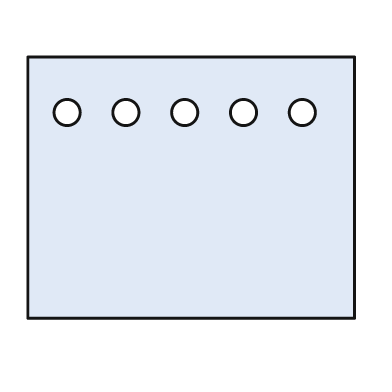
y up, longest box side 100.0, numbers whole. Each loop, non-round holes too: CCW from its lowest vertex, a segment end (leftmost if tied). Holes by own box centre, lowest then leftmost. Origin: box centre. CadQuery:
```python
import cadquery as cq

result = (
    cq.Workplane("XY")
    .moveTo(-50.0, -40.0)
    .lineTo(50.0, -40.0)
    .lineTo(50.0, 40.0)
    .lineTo(-50.0, 40.0)
    .close()
    .moveTo(-38.0, 23.0)
    .circle(4.0)
    .moveTo(-20.0, 23.0)
    .circle(4.0)
    .moveTo(-2.0, 23.0)
    .circle(4.0)
    .moveTo(16.0, 23.0)
    .circle(4.0)
    .moveTo(34.0, 23.0)
    .circle(4.0)
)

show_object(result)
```